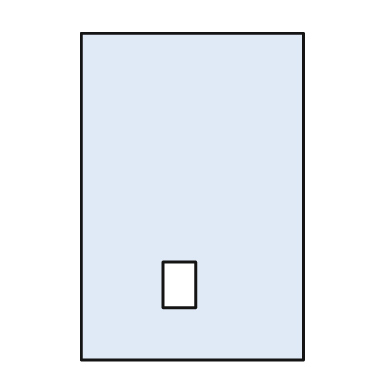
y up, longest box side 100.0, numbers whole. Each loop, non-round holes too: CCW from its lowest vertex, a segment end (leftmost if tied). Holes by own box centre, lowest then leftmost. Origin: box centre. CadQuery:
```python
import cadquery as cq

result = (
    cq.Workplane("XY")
    .moveTo(-34.0, -50.0)
    .lineTo(34.0, -50.0)
    .lineTo(34.0, 50.0)
    .lineTo(-34.0, 50.0)
    .close()
    .moveTo(-9.0, -34.0)
    .lineTo(1.0, -34.0)
    .lineTo(1.0, -20.0)
    .lineTo(-9.0, -20.0)
    .close()
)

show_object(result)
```